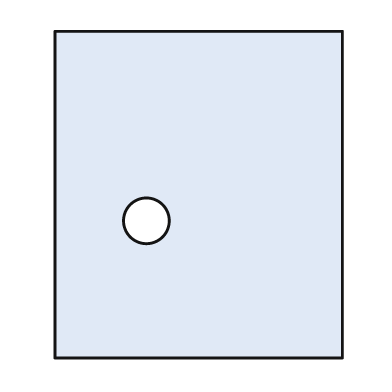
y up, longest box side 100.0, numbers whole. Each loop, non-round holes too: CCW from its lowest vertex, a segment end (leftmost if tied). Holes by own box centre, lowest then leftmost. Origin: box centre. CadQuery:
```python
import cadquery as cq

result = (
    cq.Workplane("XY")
    .moveTo(-44.0, -50.0)
    .lineTo(44.0, -50.0)
    .lineTo(44.0, 50.0)
    .lineTo(-44.0, 50.0)
    .close()
    .moveTo(-16.0, -8.0)
    .circle(7.0)
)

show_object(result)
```